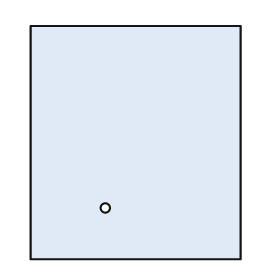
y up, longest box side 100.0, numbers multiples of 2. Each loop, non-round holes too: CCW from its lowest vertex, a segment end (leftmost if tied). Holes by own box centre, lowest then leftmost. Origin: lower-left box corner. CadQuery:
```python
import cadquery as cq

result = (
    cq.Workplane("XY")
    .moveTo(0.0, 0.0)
    .lineTo(90.0, 0.0)
    .lineTo(90.0, 100.0)
    .lineTo(0.0, 100.0)
    .close()
    .moveTo(32.0, 22.0)
    .circle(2.0)
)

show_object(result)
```